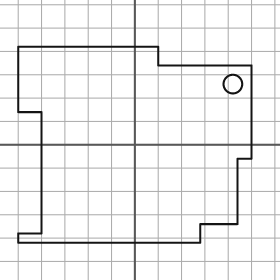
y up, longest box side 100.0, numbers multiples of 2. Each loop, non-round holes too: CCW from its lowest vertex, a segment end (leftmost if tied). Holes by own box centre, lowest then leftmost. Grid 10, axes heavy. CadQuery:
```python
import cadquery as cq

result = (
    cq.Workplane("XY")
    .moveTo(-50.0, -42.0)
    .lineTo(28.0, -42.0)
    .lineTo(28.0, -34.0)
    .lineTo(44.0, -34.0)
    .lineTo(44.0, -6.0)
    .lineTo(50.0, -6.0)
    .lineTo(50.0, 34.0)
    .lineTo(10.0, 34.0)
    .lineTo(10.0, 42.0)
    .lineTo(-50.0, 42.0)
    .lineTo(-50.0, 14.0)
    .lineTo(-40.0, 14.0)
    .lineTo(-40.0, -38.0)
    .lineTo(-50.0, -38.0)
    .close()
    .moveTo(42.0, 26.0)
    .circle(4.0)
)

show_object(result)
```